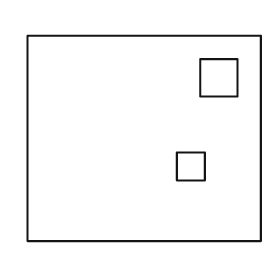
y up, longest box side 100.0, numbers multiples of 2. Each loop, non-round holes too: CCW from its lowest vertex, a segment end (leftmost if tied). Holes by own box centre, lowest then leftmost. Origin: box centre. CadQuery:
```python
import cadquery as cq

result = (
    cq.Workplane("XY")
    .moveTo(-50.0, -44.0)
    .lineTo(50.0, -44.0)
    .lineTo(50.0, 44.0)
    .lineTo(-50.0, 44.0)
    .close()
    .moveTo(14.0, -18.0)
    .lineTo(26.0, -18.0)
    .lineTo(26.0, -6.0)
    .lineTo(14.0, -6.0)
    .close()
    .moveTo(24.0, 18.0)
    .lineTo(40.0, 18.0)
    .lineTo(40.0, 34.0)
    .lineTo(24.0, 34.0)
    .close()
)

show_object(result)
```